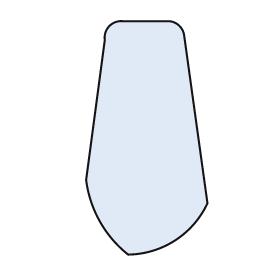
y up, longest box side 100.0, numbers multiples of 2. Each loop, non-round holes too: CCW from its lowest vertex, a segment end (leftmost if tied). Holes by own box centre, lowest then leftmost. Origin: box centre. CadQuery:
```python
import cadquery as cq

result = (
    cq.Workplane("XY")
    .moveTo(-8.0, -50.0)
    .threePointArc((12.0, -44.0), (26.0, -28.0))
    .lineTo(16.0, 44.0)
    .threePointArc((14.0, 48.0), (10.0, 50.0))
    .lineTo(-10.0, 50.0)
    .threePointArc((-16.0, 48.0), (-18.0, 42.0))
    .lineTo(-26.0, -18.0)
    .threePointArc((-20.0, -36.0), (-8.0, -50.0))
    .close()
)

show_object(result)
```